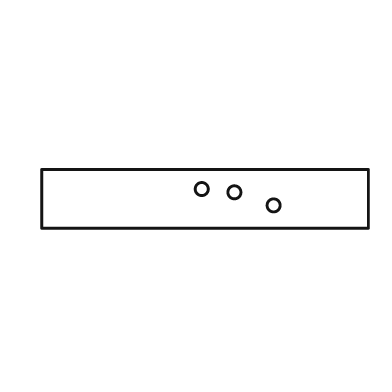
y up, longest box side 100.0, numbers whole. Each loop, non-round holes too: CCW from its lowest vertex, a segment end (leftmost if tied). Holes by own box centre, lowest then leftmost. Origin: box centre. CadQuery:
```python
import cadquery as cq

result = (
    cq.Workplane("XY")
    .moveTo(-50.0, -9.0)
    .lineTo(50.0, -9.0)
    .lineTo(50.0, 9.0)
    .lineTo(-50.0, 9.0)
    .close()
    .moveTo(21.0, -2.0)
    .circle(2.0)
    .moveTo(9.0, 2.0)
    .circle(2.0)
    .moveTo(-1.0, 3.0)
    .circle(2.0)
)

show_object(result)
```